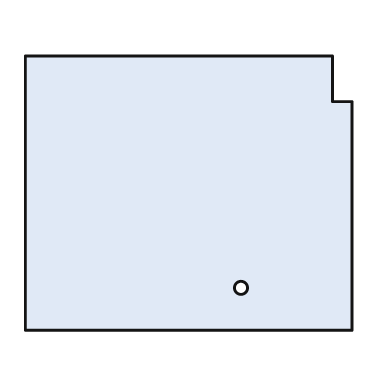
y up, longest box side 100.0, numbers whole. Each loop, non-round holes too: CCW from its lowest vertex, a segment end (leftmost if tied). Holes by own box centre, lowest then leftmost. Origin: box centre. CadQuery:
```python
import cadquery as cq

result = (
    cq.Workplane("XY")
    .moveTo(-50.0, -42.0)
    .lineTo(50.0, -42.0)
    .lineTo(50.0, 28.0)
    .lineTo(44.0, 28.0)
    .lineTo(44.0, 42.0)
    .lineTo(-50.0, 42.0)
    .close()
    .moveTo(16.0, -29.0)
    .circle(2.0)
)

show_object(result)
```